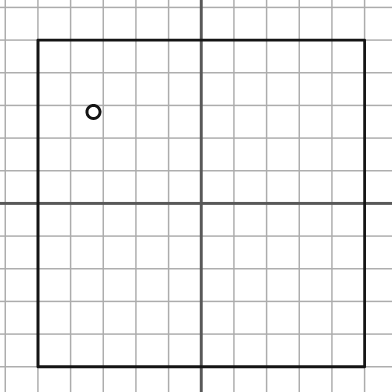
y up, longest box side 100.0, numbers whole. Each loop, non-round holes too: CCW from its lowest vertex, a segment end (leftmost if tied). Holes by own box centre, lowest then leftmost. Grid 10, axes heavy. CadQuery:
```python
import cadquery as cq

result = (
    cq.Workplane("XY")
    .moveTo(-50.0, -50.0)
    .lineTo(50.0, -50.0)
    .lineTo(50.0, 50.0)
    .lineTo(-50.0, 50.0)
    .close()
    .moveTo(-33.0, 28.0)
    .circle(2.0)
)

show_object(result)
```